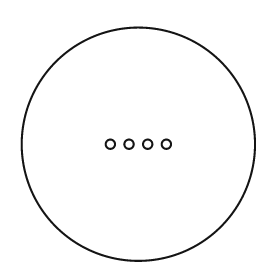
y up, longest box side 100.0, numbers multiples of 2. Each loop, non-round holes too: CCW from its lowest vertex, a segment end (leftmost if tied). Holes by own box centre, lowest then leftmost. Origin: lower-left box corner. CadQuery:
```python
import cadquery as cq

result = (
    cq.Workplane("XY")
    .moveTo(50.0, 50.0)
    .circle(50.0)
    .moveTo(38.0, 50.0)
    .circle(2.0)
    .moveTo(46.0, 50.0)
    .circle(2.0)
    .moveTo(54.0, 50.0)
    .circle(2.0)
    .moveTo(62.0, 50.0)
    .circle(2.0)
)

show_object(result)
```